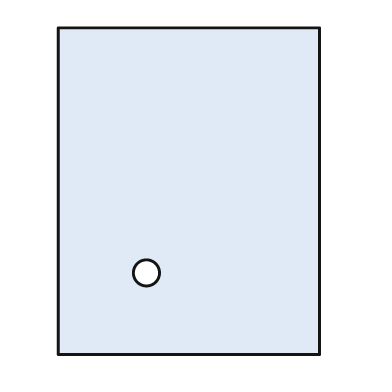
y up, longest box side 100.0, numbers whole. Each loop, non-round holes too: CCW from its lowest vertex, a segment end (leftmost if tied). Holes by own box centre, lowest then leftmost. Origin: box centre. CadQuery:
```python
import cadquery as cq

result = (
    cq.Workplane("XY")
    .moveTo(-40.0, -50.0)
    .lineTo(40.0, -50.0)
    .lineTo(40.0, 50.0)
    .lineTo(-40.0, 50.0)
    .close()
    .moveTo(-13.0, -25.0)
    .circle(4.0)
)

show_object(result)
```